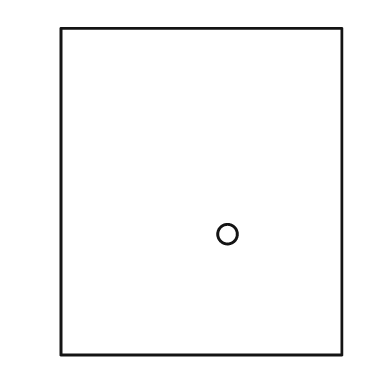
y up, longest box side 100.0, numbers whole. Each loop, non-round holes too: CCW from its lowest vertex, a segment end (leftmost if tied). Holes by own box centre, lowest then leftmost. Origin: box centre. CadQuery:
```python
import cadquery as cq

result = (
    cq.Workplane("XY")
    .moveTo(-43.0, -50.0)
    .lineTo(43.0, -50.0)
    .lineTo(43.0, 50.0)
    .lineTo(-43.0, 50.0)
    .close()
    .moveTo(8.0, -13.0)
    .circle(3.0)
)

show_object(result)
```